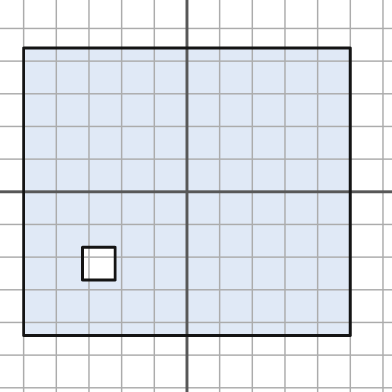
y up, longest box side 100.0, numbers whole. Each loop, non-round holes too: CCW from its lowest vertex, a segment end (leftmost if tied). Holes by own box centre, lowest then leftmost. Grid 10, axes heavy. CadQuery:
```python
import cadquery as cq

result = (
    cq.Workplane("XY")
    .moveTo(-50.0, -44.0)
    .lineTo(50.0, -44.0)
    .lineTo(50.0, 44.0)
    .lineTo(-50.0, 44.0)
    .close()
    .moveTo(-32.0, -27.0)
    .lineTo(-22.0, -27.0)
    .lineTo(-22.0, -17.0)
    .lineTo(-32.0, -17.0)
    .close()
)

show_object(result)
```